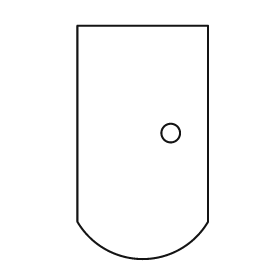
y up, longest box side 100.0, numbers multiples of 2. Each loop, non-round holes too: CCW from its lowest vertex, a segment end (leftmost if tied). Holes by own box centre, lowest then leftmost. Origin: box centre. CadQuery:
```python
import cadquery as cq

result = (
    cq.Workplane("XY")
    .moveTo(-28.0, -34.0)
    .threePointArc((0.0, -50.0), (28.0, -34.0))
    .lineTo(28.0, 50.0)
    .lineTo(-28.0, 50.0)
    .close()
    .moveTo(12.0, 4.0)
    .circle(4.0)
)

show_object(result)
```